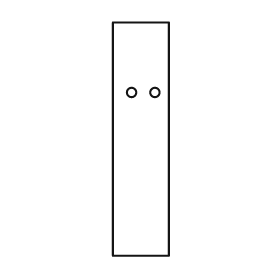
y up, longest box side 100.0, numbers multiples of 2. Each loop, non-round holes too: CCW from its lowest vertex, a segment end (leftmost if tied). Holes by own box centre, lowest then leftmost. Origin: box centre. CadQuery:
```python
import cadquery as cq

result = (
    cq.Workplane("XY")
    .moveTo(-12.0, -50.0)
    .lineTo(12.0, -50.0)
    .lineTo(12.0, 50.0)
    .lineTo(-12.0, 50.0)
    .close()
    .moveTo(-4.0, 20.0)
    .circle(2.0)
    .moveTo(6.0, 20.0)
    .circle(2.0)
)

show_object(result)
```